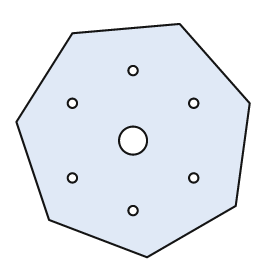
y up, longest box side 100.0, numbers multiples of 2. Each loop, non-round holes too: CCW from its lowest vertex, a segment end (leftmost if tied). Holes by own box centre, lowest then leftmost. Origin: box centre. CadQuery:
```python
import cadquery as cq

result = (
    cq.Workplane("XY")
    .moveTo(6.0, -50.0)
    .lineTo(44.0, -28.0)
    .lineTo(50.0, 16.0)
    .lineTo(20.0, 50.0)
    .lineTo(-26.0, 46.0)
    .lineTo(-50.0, 8.0)
    .lineTo(-36.0, -34.0)
    .close()
    .moveTo(0.0, -30.0)
    .circle(2.0)
    .moveTo(-26.0, -16.0)
    .circle(2.0)
    .moveTo(26.0, -16.0)
    .circle(2.0)
    .moveTo(0.0, 0.0)
    .circle(6.0)
    .moveTo(-26.0, 16.0)
    .circle(2.0)
    .moveTo(26.0, 16.0)
    .circle(2.0)
    .moveTo(0.0, 30.0)
    .circle(2.0)
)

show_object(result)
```